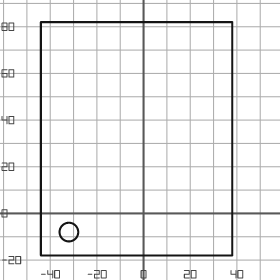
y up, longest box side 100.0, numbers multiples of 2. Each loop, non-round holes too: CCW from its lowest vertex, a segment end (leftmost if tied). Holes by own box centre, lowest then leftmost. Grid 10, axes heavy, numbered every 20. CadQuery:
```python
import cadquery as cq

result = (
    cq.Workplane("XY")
    .moveTo(-44.0, -18.0)
    .lineTo(38.0, -18.0)
    .lineTo(38.0, 82.0)
    .lineTo(-44.0, 82.0)
    .close()
    .moveTo(-32.0, -8.0)
    .circle(4.0)
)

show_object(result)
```